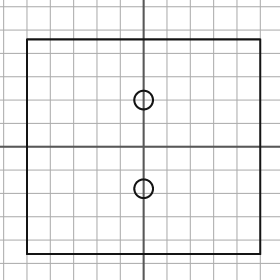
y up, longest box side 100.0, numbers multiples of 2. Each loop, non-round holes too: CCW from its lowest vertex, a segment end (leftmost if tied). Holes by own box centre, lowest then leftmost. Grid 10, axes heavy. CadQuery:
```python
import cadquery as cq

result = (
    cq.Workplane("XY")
    .moveTo(-50.0, -46.0)
    .lineTo(50.0, -46.0)
    .lineTo(50.0, 46.0)
    .lineTo(-50.0, 46.0)
    .close()
    .moveTo(0.0, -18.0)
    .circle(4.0)
    .moveTo(0.0, 20.0)
    .circle(4.0)
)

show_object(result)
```